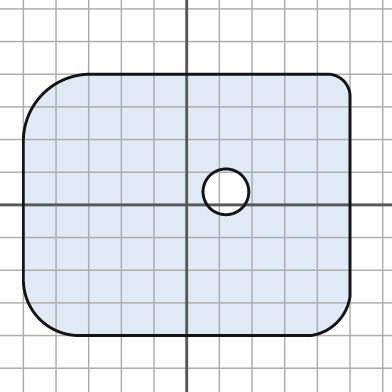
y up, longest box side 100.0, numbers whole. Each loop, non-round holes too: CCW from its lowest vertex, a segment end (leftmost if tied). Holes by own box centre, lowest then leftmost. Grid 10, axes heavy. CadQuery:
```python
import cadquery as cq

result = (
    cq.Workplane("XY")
    .moveTo(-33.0, -40.0)
    .lineTo(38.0, -40.0)
    .threePointArc((46.0, -36.0), (50.0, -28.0))
    .lineTo(50.0, 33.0)
    .threePointArc((48.0, 38.0), (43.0, 40.0))
    .lineTo(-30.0, 40.0)
    .threePointArc((-44.0, 34.0), (-50.0, 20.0))
    .lineTo(-50.0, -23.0)
    .threePointArc((-45.0, -35.0), (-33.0, -40.0))
    .close()
    .moveTo(12.0, 4.0)
    .circle(7.0)
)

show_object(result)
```